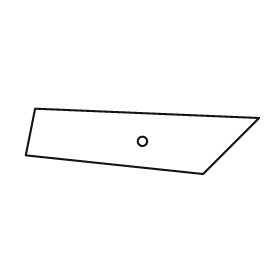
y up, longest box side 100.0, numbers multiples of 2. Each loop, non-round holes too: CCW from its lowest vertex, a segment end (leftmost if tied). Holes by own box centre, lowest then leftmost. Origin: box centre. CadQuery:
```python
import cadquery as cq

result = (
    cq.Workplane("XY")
    .moveTo(26.0, -14.0)
    .lineTo(50.0, 10.0)
    .lineTo(-46.0, 14.0)
    .lineTo(-50.0, -6.0)
    .close()
    .moveTo(0.0, 0.0)
    .circle(2.0)
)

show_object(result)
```